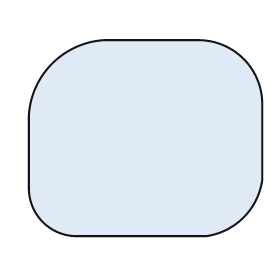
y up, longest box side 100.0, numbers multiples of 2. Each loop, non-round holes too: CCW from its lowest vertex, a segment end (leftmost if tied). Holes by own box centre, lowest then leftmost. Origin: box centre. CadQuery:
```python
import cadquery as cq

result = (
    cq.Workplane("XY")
    .moveTo(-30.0, -42.0)
    .lineTo(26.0, -42.0)
    .threePointArc((42.0, -34.0), (50.0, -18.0))
    .lineTo(50.0, 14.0)
    .threePointArc((42.0, 34.0), (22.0, 42.0))
    .lineTo(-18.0, 42.0)
    .threePointArc((-40.0, 32.0), (-50.0, 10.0))
    .lineTo(-50.0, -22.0)
    .threePointArc((-44.0, -36.0), (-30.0, -42.0))
    .close()
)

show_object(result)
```